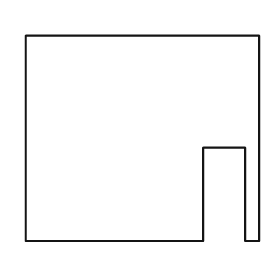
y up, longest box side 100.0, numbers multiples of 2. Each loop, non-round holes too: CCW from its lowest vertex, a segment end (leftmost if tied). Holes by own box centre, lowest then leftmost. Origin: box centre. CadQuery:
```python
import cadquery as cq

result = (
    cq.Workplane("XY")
    .moveTo(-50.0, -44.0)
    .lineTo(26.0, -44.0)
    .lineTo(26.0, -4.0)
    .lineTo(44.0, -4.0)
    .lineTo(44.0, -44.0)
    .lineTo(50.0, -44.0)
    .lineTo(50.0, 44.0)
    .lineTo(-50.0, 44.0)
    .close()
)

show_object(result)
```